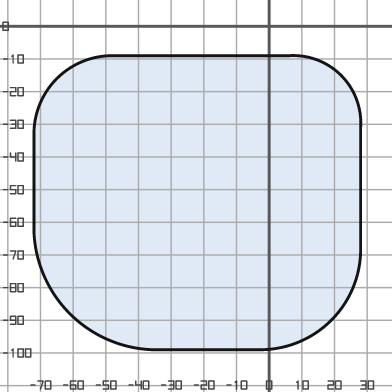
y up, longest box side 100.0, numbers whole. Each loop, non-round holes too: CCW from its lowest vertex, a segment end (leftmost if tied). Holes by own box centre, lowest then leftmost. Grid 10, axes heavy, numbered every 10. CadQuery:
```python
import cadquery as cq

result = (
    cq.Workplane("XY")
    .moveTo(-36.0, -99.0)
    .lineTo(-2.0, -99.0)
    .threePointArc((19.0, -90.0), (28.0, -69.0))
    .lineTo(28.0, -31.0)
    .threePointArc((22.0, -15.0), (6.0, -9.0))
    .lineTo(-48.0, -9.0)
    .threePointArc((-65.0, -16.0), (-72.0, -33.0))
    .lineTo(-72.0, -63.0)
    .threePointArc((-61.0, -88.0), (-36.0, -99.0))
    .close()
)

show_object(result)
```